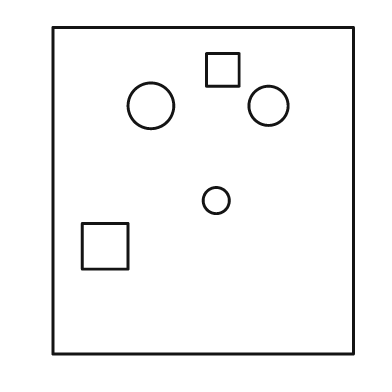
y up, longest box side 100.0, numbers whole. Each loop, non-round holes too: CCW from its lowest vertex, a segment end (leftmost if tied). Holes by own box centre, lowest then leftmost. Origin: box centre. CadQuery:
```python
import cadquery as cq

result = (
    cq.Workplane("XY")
    .moveTo(-46.0, -50.0)
    .lineTo(46.0, -50.0)
    .lineTo(46.0, 50.0)
    .lineTo(-46.0, 50.0)
    .close()
    .moveTo(-37.0, -24.0)
    .lineTo(-23.0, -24.0)
    .lineTo(-23.0, -10.0)
    .lineTo(-37.0, -10.0)
    .close()
    .moveTo(4.0, -3.0)
    .circle(4.0)
    .moveTo(-16.0, 26.0)
    .circle(7.0)
    .moveTo(20.0, 26.0)
    .circle(6.0)
    .moveTo(1.0, 32.0)
    .lineTo(11.0, 32.0)
    .lineTo(11.0, 42.0)
    .lineTo(1.0, 42.0)
    .close()
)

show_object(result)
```